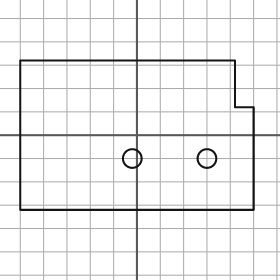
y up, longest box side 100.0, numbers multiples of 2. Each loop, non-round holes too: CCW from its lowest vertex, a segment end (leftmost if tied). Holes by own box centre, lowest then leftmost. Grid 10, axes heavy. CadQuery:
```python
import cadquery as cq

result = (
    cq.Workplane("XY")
    .moveTo(-50.0, -32.0)
    .lineTo(50.0, -32.0)
    .lineTo(50.0, 12.0)
    .lineTo(42.0, 12.0)
    .lineTo(42.0, 32.0)
    .lineTo(-50.0, 32.0)
    .close()
    .moveTo(-2.0, -10.0)
    .circle(4.0)
    .moveTo(30.0, -10.0)
    .circle(4.0)
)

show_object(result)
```